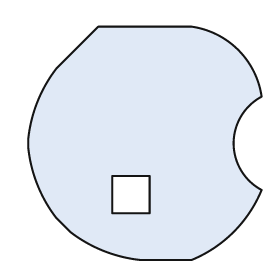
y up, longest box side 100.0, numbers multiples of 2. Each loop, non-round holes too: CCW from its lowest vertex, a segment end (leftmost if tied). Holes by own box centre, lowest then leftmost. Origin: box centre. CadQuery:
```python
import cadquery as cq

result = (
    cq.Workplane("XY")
    .moveTo(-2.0, -50.0)
    .lineTo(20.0, -50.0)
    .threePointArc((38.0, -38.0), (50.0, -20.0))
    .threePointArc((38.0, 0.0), (50.0, 20.0))
    .threePointArc((40.0, 40.0), (20.0, 50.0))
    .lineTo(-20.0, 50.0)
    .lineTo(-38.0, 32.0)
    .threePointArc((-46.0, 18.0), (-50.0, 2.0))
    .lineTo(-50.0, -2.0)
    .threePointArc((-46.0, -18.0), (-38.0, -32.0))
    .lineTo(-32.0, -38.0)
    .threePointArc((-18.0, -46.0), (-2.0, -50.0))
    .close()
    .moveTo(-14.0, -30.0)
    .lineTo(2.0, -30.0)
    .lineTo(2.0, -14.0)
    .lineTo(-14.0, -14.0)
    .close()
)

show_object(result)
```